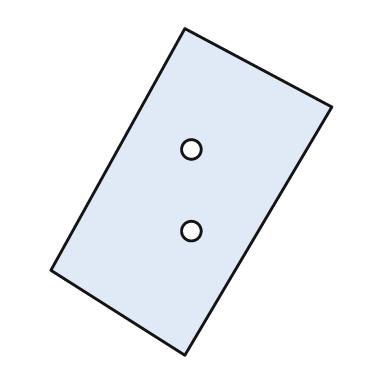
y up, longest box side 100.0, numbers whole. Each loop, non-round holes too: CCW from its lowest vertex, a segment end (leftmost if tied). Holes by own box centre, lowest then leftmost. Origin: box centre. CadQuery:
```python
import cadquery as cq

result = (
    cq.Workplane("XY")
    .moveTo(-2.0, -50.0)
    .lineTo(43.0, 26.0)
    .lineTo(-2.0, 50.0)
    .lineTo(-43.0, -24.0)
    .close()
    .moveTo(0.0, -12.0)
    .circle(3.0)
    .moveTo(0.0, 13.0)
    .circle(3.0)
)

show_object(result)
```